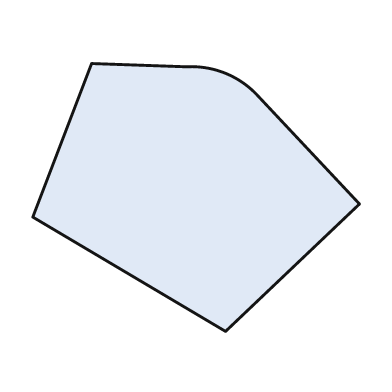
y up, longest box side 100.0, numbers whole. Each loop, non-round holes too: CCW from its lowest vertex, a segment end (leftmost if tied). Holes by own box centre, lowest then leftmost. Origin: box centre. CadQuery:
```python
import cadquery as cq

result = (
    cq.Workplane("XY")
    .moveTo(9.0, -41.0)
    .lineTo(50.0, -2.0)
    .lineTo(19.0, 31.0)
    .threePointArc((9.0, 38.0), (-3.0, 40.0))
    .lineTo(-32.0, 41.0)
    .lineTo(-50.0, -6.0)
    .close()
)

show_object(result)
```